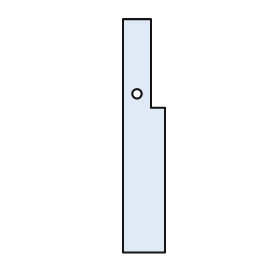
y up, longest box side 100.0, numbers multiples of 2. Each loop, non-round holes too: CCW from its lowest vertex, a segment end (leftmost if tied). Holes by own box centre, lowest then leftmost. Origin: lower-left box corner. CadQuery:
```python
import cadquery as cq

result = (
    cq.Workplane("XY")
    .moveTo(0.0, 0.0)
    .lineTo(18.0, 0.0)
    .lineTo(18.0, 62.0)
    .lineTo(12.0, 62.0)
    .lineTo(12.0, 100.0)
    .lineTo(0.0, 100.0)
    .close()
    .moveTo(6.0, 68.0)
    .circle(2.0)
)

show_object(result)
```